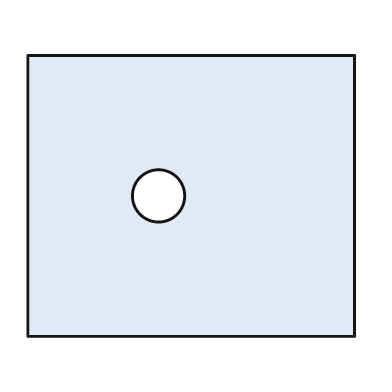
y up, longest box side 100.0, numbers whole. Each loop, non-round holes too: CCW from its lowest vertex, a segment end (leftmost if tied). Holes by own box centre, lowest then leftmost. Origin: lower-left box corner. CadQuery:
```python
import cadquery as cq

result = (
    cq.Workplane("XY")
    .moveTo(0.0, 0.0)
    .lineTo(100.0, 0.0)
    .lineTo(100.0, 86.0)
    .lineTo(0.0, 86.0)
    .close()
    .moveTo(40.0, 43.0)
    .circle(8.0)
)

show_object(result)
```